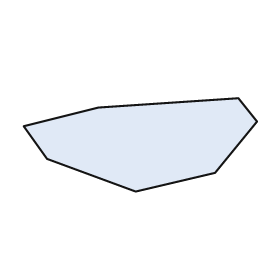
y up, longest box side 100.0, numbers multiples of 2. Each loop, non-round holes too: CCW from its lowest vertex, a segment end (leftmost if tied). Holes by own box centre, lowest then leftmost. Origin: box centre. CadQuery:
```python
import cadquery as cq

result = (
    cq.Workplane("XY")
    .moveTo(-2.0, -20.0)
    .lineTo(32.0, -12.0)
    .lineTo(50.0, 10.0)
    .lineTo(42.0, 20.0)
    .lineTo(-18.0, 16.0)
    .lineTo(-50.0, 8.0)
    .lineTo(-40.0, -6.0)
    .close()
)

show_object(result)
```